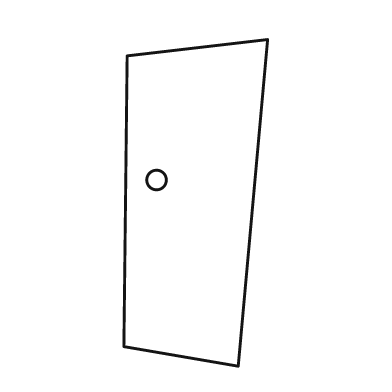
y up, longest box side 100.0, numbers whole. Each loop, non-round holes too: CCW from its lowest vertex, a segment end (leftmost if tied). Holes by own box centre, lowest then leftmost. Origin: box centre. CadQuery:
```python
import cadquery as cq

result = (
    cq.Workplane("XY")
    .moveTo(13.0, -50.0)
    .lineTo(22.0, 50.0)
    .lineTo(-21.0, 45.0)
    .lineTo(-22.0, -44.0)
    .close()
    .moveTo(-12.0, 7.0)
    .circle(3.0)
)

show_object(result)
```